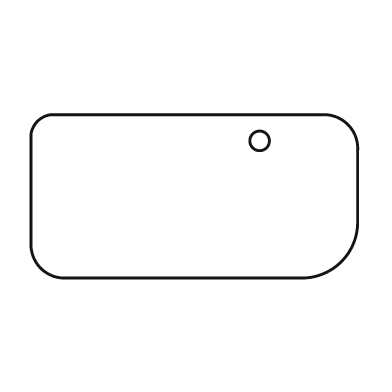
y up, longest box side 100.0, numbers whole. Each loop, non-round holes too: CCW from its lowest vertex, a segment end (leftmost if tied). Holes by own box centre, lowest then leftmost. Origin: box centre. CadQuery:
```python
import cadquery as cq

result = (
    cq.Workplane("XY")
    .moveTo(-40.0, -25.0)
    .lineTo(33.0, -25.0)
    .threePointArc((45.0, -20.0), (50.0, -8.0))
    .lineTo(50.0, 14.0)
    .threePointArc((47.0, 22.0), (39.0, 25.0))
    .lineTo(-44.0, 25.0)
    .threePointArc((-48.0, 23.0), (-50.0, 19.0))
    .lineTo(-50.0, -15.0)
    .threePointArc((-47.0, -22.0), (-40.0, -25.0))
    .close()
    .moveTo(20.0, 17.0)
    .circle(3.0)
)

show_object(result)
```